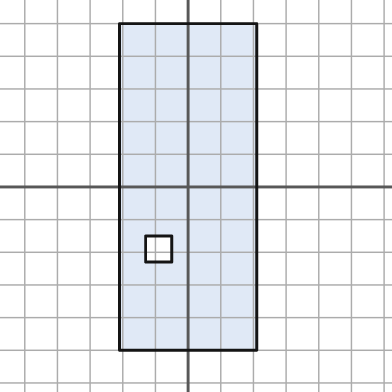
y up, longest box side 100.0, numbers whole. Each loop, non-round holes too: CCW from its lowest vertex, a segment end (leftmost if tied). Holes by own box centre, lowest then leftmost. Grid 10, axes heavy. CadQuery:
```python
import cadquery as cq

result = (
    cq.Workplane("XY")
    .moveTo(-21.0, -50.0)
    .lineTo(21.0, -50.0)
    .lineTo(21.0, 50.0)
    .lineTo(-21.0, 50.0)
    .close()
    .moveTo(-13.0, -23.0)
    .lineTo(-5.0, -23.0)
    .lineTo(-5.0, -15.0)
    .lineTo(-13.0, -15.0)
    .close()
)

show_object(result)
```